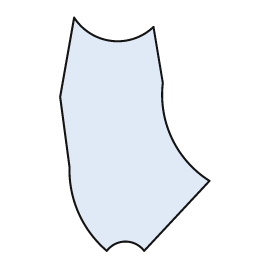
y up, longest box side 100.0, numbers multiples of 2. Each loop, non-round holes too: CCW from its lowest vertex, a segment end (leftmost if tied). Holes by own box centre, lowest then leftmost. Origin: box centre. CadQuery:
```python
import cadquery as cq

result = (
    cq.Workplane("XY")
    .moveTo(-12.0, -50.0)
    .threePointArc((-4.0, -46.0), (4.0, -50.0))
    .lineTo(32.0, -20.0)
    .threePointArc((16.0, -2.0), (12.0, 22.0))
    .lineTo(8.0, 46.0)
    .threePointArc((-10.0, 40.0), (-26.0, 50.0))
    .lineTo(-32.0, 16.0)
    .lineTo(-28.0, -14.0)
    .threePointArc((-24.0, -34.0), (-12.0, -50.0))
    .close()
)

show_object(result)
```